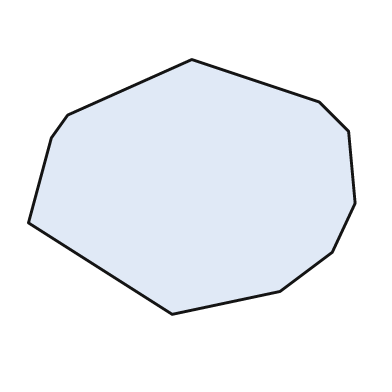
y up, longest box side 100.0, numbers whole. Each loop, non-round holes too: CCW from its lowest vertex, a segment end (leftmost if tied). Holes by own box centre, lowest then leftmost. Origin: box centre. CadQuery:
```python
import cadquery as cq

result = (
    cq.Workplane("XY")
    .moveTo(-6.0, -39.0)
    .lineTo(27.0, -32.0)
    .lineTo(43.0, -20.0)
    .lineTo(50.0, -5.0)
    .lineTo(48.0, 17.0)
    .lineTo(39.0, 26.0)
    .lineTo(0.0, 39.0)
    .lineTo(-38.0, 22.0)
    .lineTo(-43.0, 15.0)
    .lineTo(-50.0, -11.0)
    .close()
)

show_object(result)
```